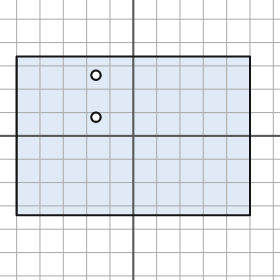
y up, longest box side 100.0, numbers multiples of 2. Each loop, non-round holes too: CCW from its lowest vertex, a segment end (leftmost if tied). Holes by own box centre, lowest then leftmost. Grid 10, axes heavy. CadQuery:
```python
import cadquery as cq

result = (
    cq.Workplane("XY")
    .moveTo(-50.0, -34.0)
    .lineTo(50.0, -34.0)
    .lineTo(50.0, 34.0)
    .lineTo(-50.0, 34.0)
    .close()
    .moveTo(-16.0, 8.0)
    .circle(2.0)
    .moveTo(-16.0, 26.0)
    .circle(2.0)
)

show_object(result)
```